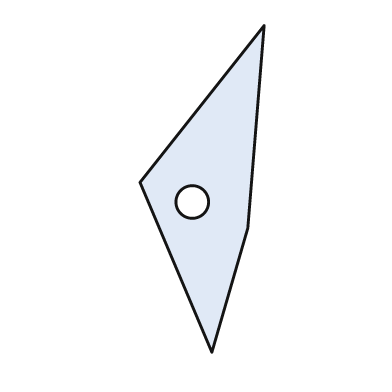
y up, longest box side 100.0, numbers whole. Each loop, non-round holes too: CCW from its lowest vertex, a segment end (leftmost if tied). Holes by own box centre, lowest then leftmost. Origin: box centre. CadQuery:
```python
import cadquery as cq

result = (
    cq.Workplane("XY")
    .moveTo(3.0, -50.0)
    .lineTo(14.0, -12.0)
    .lineTo(19.0, 50.0)
    .lineTo(-19.0, 2.0)
    .close()
    .moveTo(-3.0, -4.0)
    .circle(5.0)
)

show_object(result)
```